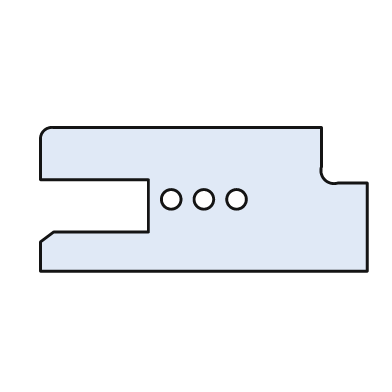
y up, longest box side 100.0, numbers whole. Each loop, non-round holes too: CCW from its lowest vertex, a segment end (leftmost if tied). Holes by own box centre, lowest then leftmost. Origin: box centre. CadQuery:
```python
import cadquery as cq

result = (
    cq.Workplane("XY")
    .moveTo(-50.0, -22.0)
    .lineTo(50.0, -22.0)
    .lineTo(50.0, 5.0)
    .lineTo(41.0, 5.0)
    .threePointArc((37.0, 6.0), (36.0, 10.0))
    .lineTo(36.0, 22.0)
    .lineTo(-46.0, 22.0)
    .threePointArc((-49.0, 21.0), (-50.0, 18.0))
    .lineTo(-50.0, 6.0)
    .lineTo(-17.0, 6.0)
    .lineTo(-17.0, -10.0)
    .lineTo(-46.0, -10.0)
    .lineTo(-50.0, -13.0)
    .close()
    .moveTo(-10.0, 0.0)
    .circle(3.0)
    .moveTo(0.0, 0.0)
    .circle(3.0)
    .moveTo(10.0, 0.0)
    .circle(3.0)
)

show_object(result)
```